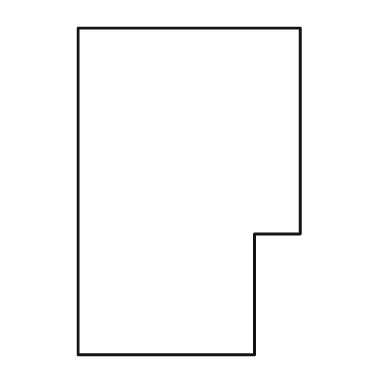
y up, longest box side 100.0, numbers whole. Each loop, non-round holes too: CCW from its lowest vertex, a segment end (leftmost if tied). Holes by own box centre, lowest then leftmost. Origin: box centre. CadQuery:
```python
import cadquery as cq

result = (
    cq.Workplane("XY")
    .moveTo(-34.0, -50.0)
    .lineTo(20.0, -50.0)
    .lineTo(20.0, -13.0)
    .lineTo(34.0, -13.0)
    .lineTo(34.0, 50.0)
    .lineTo(-34.0, 50.0)
    .close()
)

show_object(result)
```